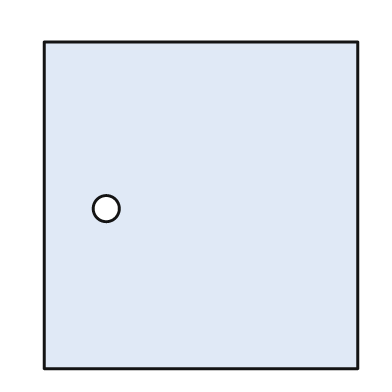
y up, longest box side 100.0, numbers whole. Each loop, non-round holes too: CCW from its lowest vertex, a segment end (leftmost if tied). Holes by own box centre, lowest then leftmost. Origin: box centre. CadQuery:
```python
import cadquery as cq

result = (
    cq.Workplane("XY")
    .moveTo(-48.0, -50.0)
    .lineTo(48.0, -50.0)
    .lineTo(48.0, 50.0)
    .lineTo(-48.0, 50.0)
    .close()
    .moveTo(-29.0, -1.0)
    .circle(4.0)
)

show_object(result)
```